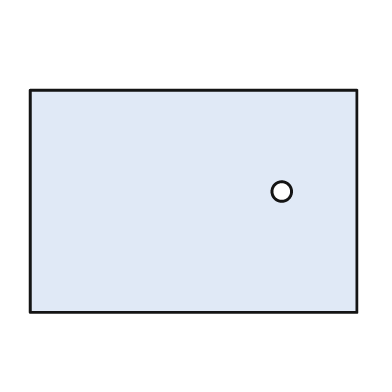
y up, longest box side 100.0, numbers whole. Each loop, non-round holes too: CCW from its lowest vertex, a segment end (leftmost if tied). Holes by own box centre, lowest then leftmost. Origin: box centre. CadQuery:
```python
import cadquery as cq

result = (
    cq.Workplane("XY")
    .moveTo(-50.0, -34.0)
    .lineTo(50.0, -34.0)
    .lineTo(50.0, 34.0)
    .lineTo(-50.0, 34.0)
    .close()
    .moveTo(27.0, 3.0)
    .circle(3.0)
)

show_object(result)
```